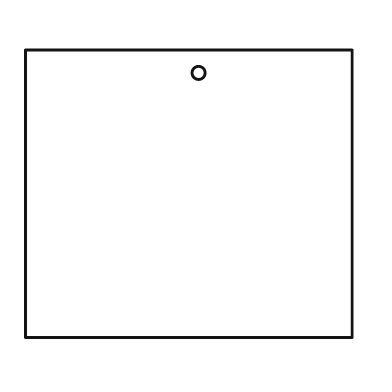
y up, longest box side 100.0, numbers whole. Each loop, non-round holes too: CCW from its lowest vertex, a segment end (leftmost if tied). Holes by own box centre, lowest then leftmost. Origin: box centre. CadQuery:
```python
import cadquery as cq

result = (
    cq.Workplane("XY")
    .moveTo(-50.0, -44.0)
    .lineTo(50.0, -44.0)
    .lineTo(50.0, 44.0)
    .lineTo(-50.0, 44.0)
    .close()
    .moveTo(3.0, 37.0)
    .circle(2.0)
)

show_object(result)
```